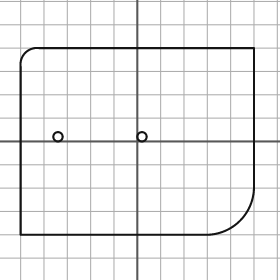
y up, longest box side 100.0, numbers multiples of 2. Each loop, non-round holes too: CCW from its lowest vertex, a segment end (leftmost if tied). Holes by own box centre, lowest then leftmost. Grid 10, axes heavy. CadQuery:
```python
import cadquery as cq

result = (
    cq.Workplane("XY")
    .moveTo(-50.0, -40.0)
    .lineTo(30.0, -40.0)
    .threePointArc((44.0, -34.0), (50.0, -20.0))
    .lineTo(50.0, 40.0)
    .lineTo(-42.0, 40.0)
    .threePointArc((-48.0, 38.0), (-50.0, 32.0))
    .close()
    .moveTo(-34.0, 2.0)
    .circle(2.0)
    .moveTo(2.0, 2.0)
    .circle(2.0)
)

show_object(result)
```